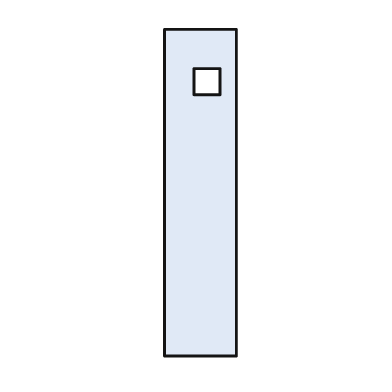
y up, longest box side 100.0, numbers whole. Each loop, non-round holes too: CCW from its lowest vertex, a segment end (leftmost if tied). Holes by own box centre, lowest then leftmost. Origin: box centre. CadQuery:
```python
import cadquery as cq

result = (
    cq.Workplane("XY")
    .moveTo(-11.0, -50.0)
    .lineTo(11.0, -50.0)
    .lineTo(11.0, 50.0)
    .lineTo(-11.0, 50.0)
    .close()
    .moveTo(-2.0, 30.0)
    .lineTo(6.0, 30.0)
    .lineTo(6.0, 38.0)
    .lineTo(-2.0, 38.0)
    .close()
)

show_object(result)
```